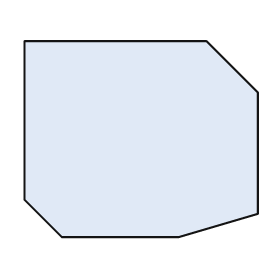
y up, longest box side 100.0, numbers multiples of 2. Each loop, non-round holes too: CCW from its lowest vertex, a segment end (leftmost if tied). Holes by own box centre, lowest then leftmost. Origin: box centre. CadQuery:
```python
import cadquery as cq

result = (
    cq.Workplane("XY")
    .moveTo(-34.0, -42.0)
    .lineTo(16.0, -42.0)
    .lineTo(50.0, -32.0)
    .lineTo(50.0, 20.0)
    .lineTo(28.0, 42.0)
    .lineTo(-50.0, 42.0)
    .lineTo(-50.0, -26.0)
    .close()
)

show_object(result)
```